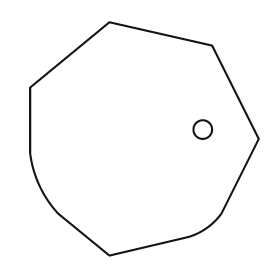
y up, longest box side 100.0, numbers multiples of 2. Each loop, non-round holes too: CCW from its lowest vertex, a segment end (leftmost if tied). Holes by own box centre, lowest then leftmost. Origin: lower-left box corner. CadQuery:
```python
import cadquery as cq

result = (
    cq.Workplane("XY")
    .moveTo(34.0, 0.0)
    .lineTo(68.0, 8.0)
    .threePointArc((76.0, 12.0), (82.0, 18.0))
    .lineTo(98.0, 50.0)
    .lineTo(78.0, 90.0)
    .lineTo(34.0, 100.0)
    .lineTo(0.0, 72.0)
    .lineTo(0.0, 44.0)
    .threePointArc((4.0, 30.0), (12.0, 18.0))
    .close()
    .moveTo(74.0, 54.0)
    .circle(4.0)
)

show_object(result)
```